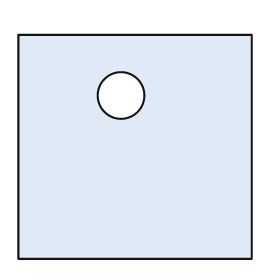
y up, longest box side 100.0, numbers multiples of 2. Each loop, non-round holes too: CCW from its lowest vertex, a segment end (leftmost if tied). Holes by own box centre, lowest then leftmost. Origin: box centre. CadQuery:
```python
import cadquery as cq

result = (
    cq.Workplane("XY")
    .moveTo(-50.0, -48.0)
    .lineTo(50.0, -48.0)
    .lineTo(50.0, 48.0)
    .lineTo(-50.0, 48.0)
    .close()
    .moveTo(-6.0, 22.0)
    .circle(10.0)
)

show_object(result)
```